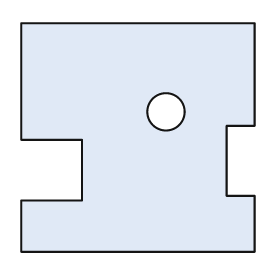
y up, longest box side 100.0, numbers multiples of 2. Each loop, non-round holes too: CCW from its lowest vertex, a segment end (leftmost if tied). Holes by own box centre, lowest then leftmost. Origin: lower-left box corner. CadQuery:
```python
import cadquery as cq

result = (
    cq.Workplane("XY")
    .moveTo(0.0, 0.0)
    .lineTo(100.0, 0.0)
    .lineTo(100.0, 24.0)
    .lineTo(88.0, 24.0)
    .lineTo(88.0, 54.0)
    .lineTo(100.0, 54.0)
    .lineTo(100.0, 98.0)
    .lineTo(0.0, 98.0)
    .lineTo(0.0, 48.0)
    .lineTo(26.0, 48.0)
    .lineTo(26.0, 22.0)
    .lineTo(0.0, 22.0)
    .close()
    .moveTo(62.0, 60.0)
    .circle(8.0)
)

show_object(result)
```